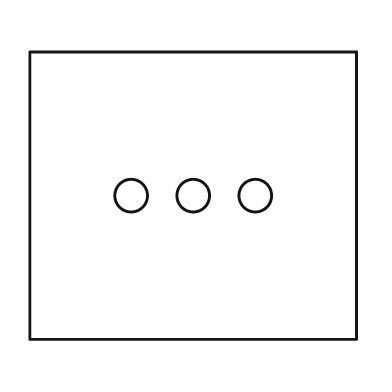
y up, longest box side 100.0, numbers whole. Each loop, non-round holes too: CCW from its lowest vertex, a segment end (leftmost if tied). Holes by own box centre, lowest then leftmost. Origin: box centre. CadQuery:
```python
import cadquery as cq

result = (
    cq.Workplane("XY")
    .moveTo(-50.0, -44.0)
    .lineTo(50.0, -44.0)
    .lineTo(50.0, 44.0)
    .lineTo(-50.0, 44.0)
    .close()
    .moveTo(-19.0, 0.0)
    .circle(5.0)
    .moveTo(0.0, 0.0)
    .circle(5.0)
    .moveTo(19.0, 0.0)
    .circle(5.0)
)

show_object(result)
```